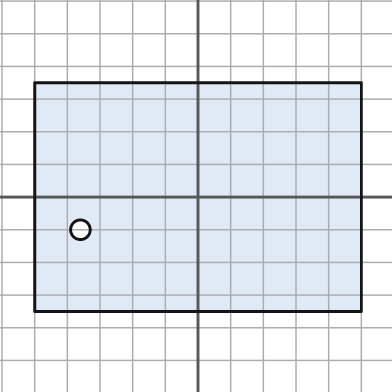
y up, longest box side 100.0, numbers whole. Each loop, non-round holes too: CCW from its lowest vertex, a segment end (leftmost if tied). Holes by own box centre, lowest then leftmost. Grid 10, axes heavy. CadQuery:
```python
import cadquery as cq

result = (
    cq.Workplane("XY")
    .moveTo(-50.0, -35.0)
    .lineTo(50.0, -35.0)
    .lineTo(50.0, 35.0)
    .lineTo(-50.0, 35.0)
    .close()
    .moveTo(-36.0, -10.0)
    .circle(3.0)
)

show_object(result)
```